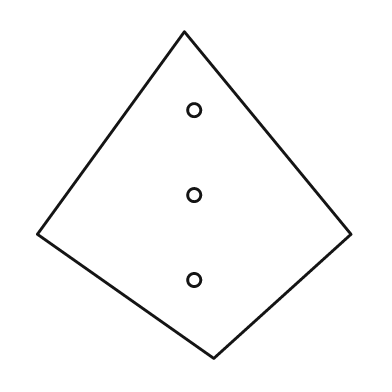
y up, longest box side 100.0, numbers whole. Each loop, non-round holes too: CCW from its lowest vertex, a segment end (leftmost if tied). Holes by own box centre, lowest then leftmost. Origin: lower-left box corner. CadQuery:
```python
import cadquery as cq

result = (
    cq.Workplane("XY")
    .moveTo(54.0, 0.0)
    .lineTo(96.0, 38.0)
    .lineTo(45.0, 100.0)
    .lineTo(0.0, 38.0)
    .close()
    .moveTo(48.0, 24.0)
    .circle(2.0)
    .moveTo(48.0, 50.0)
    .circle(2.0)
    .moveTo(48.0, 76.0)
    .circle(2.0)
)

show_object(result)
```